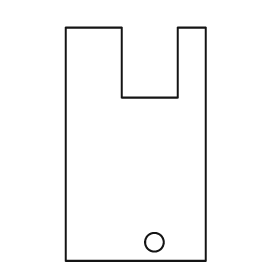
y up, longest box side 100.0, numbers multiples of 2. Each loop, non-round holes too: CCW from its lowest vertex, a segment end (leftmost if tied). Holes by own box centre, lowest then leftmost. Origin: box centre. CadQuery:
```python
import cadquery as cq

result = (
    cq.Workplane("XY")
    .moveTo(-30.0, -50.0)
    .lineTo(30.0, -50.0)
    .lineTo(30.0, 50.0)
    .lineTo(18.0, 50.0)
    .lineTo(18.0, 20.0)
    .lineTo(-6.0, 20.0)
    .lineTo(-6.0, 50.0)
    .lineTo(-30.0, 50.0)
    .close()
    .moveTo(8.0, -42.0)
    .circle(4.0)
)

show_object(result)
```